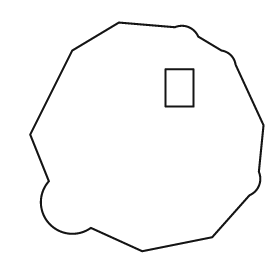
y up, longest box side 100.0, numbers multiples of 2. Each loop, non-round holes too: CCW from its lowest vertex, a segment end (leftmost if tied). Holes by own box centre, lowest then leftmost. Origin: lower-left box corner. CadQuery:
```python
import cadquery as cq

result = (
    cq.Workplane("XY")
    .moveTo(48.0, 0.0)
    .lineTo(78.0, 6.0)
    .lineTo(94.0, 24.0)
    .threePointArc((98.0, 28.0), (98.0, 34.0))
    .lineTo(100.0, 54.0)
    .lineTo(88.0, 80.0)
    .threePointArc((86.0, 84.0), (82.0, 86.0))
    .lineTo(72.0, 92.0)
    .threePointArc((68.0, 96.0), (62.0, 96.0))
    .lineTo(38.0, 98.0)
    .lineTo(18.0, 86.0)
    .lineTo(0.0, 50.0)
    .lineTo(8.0, 30.0)
    .threePointArc((8.0, 12.0), (26.0, 10.0))
    .close()
    .moveTo(58.0, 62.0)
    .lineTo(70.0, 62.0)
    .lineTo(70.0, 78.0)
    .lineTo(58.0, 78.0)
    .close()
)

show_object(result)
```